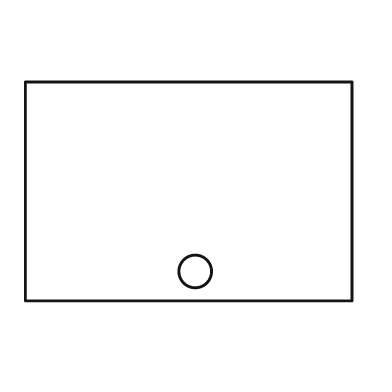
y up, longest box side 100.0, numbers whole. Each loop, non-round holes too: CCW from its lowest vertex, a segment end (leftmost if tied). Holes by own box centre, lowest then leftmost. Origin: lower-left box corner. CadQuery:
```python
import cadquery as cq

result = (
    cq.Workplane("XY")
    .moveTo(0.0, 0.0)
    .lineTo(100.0, 0.0)
    .lineTo(100.0, 67.0)
    .lineTo(0.0, 67.0)
    .close()
    .moveTo(52.0, 9.0)
    .circle(5.0)
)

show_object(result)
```